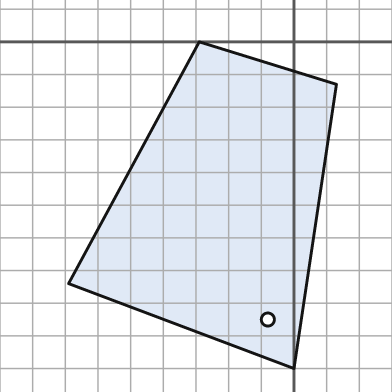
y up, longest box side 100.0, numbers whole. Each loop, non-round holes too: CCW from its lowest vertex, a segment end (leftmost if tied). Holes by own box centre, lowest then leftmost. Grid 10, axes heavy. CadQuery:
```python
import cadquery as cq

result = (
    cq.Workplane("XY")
    .moveTo(0.0, -100.0)
    .lineTo(13.0, -13.0)
    .lineTo(-29.0, 0.0)
    .lineTo(-69.0, -74.0)
    .close()
    .moveTo(-8.0, -85.0)
    .circle(2.0)
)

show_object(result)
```